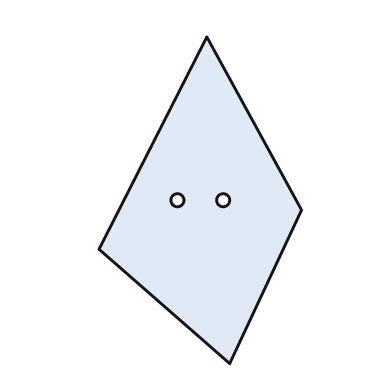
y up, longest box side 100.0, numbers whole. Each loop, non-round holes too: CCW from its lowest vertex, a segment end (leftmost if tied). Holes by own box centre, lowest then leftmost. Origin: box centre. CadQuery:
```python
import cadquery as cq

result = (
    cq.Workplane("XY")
    .moveTo(9.0, -50.0)
    .lineTo(31.0, -3.0)
    .lineTo(2.0, 50.0)
    .lineTo(-31.0, -15.0)
    .close()
    .moveTo(-7.0, 0.0)
    .circle(2.0)
    .moveTo(7.0, 0.0)
    .circle(2.0)
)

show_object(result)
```